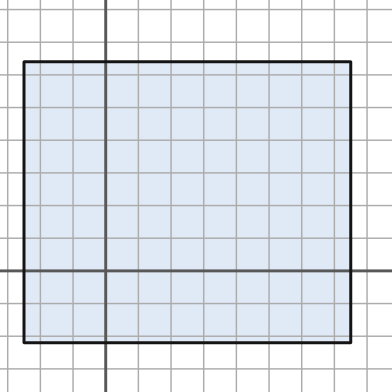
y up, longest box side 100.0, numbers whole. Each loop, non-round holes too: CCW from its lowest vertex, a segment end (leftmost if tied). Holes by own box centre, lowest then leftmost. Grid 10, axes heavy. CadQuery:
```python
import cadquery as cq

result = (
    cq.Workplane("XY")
    .moveTo(-25.0, -22.0)
    .lineTo(75.0, -22.0)
    .lineTo(75.0, 64.0)
    .lineTo(-25.0, 64.0)
    .close()
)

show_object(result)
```